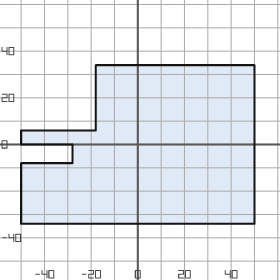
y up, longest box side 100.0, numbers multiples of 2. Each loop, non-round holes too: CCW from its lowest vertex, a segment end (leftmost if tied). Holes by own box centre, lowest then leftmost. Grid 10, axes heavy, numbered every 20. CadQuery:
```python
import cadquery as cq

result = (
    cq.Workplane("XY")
    .moveTo(-50.0, -34.0)
    .lineTo(50.0, -34.0)
    .lineTo(50.0, 34.0)
    .lineTo(-18.0, 34.0)
    .lineTo(-18.0, 6.0)
    .lineTo(-50.0, 6.0)
    .lineTo(-50.0, 0.0)
    .lineTo(-28.0, 0.0)
    .lineTo(-28.0, -8.0)
    .lineTo(-50.0, -8.0)
    .close()
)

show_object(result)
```